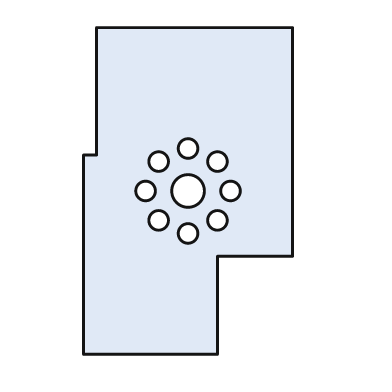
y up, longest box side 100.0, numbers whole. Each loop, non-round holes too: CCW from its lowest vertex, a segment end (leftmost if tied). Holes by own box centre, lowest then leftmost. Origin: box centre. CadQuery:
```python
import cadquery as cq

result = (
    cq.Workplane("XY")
    .moveTo(-32.0, -50.0)
    .lineTo(9.0, -50.0)
    .lineTo(9.0, -20.0)
    .lineTo(32.0, -20.0)
    .lineTo(32.0, 50.0)
    .lineTo(-28.0, 50.0)
    .lineTo(-28.0, 11.0)
    .lineTo(-32.0, 11.0)
    .close()
    .moveTo(0.0, -13.0)
    .circle(3.0)
    .moveTo(-9.0, -9.0)
    .circle(3.0)
    .moveTo(9.0, -9.0)
    .circle(3.0)
    .moveTo(-13.0, 0.0)
    .circle(3.0)
    .moveTo(0.0, 0.0)
    .circle(5.0)
    .moveTo(13.0, 0.0)
    .circle(3.0)
    .moveTo(-9.0, 9.0)
    .circle(3.0)
    .moveTo(9.0, 9.0)
    .circle(3.0)
    .moveTo(0.0, 13.0)
    .circle(3.0)
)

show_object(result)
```